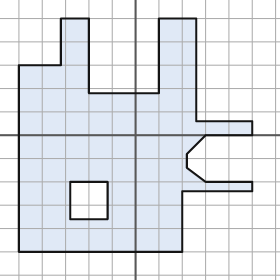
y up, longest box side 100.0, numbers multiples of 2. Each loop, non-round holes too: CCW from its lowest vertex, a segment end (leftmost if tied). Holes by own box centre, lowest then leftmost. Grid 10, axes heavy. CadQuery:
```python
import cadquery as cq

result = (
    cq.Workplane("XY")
    .moveTo(-50.0, -50.0)
    .lineTo(20.0, -50.0)
    .lineTo(20.0, -24.0)
    .lineTo(50.0, -24.0)
    .lineTo(50.0, -20.0)
    .lineTo(30.0, -20.0)
    .lineTo(22.0, -14.0)
    .lineTo(22.0, -8.0)
    .lineTo(30.0, 0.0)
    .lineTo(50.0, 0.0)
    .lineTo(50.0, 6.0)
    .lineTo(26.0, 6.0)
    .lineTo(26.0, 50.0)
    .lineTo(10.0, 50.0)
    .lineTo(10.0, 18.0)
    .lineTo(-20.0, 18.0)
    .lineTo(-20.0, 50.0)
    .lineTo(-32.0, 50.0)
    .lineTo(-32.0, 30.0)
    .lineTo(-50.0, 30.0)
    .close()
    .moveTo(-28.0, -36.0)
    .lineTo(-12.0, -36.0)
    .lineTo(-12.0, -20.0)
    .lineTo(-28.0, -20.0)
    .close()
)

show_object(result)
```